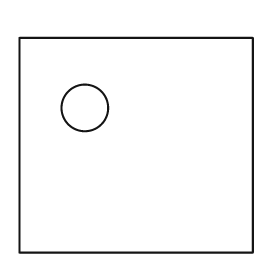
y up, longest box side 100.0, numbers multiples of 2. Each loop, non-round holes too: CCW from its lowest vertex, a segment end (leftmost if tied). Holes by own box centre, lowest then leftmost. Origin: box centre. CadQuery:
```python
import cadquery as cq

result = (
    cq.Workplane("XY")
    .moveTo(-50.0, -46.0)
    .lineTo(50.0, -46.0)
    .lineTo(50.0, 46.0)
    .lineTo(-50.0, 46.0)
    .close()
    .moveTo(-22.0, 16.0)
    .circle(10.0)
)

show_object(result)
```